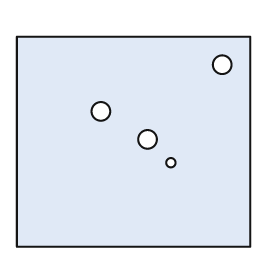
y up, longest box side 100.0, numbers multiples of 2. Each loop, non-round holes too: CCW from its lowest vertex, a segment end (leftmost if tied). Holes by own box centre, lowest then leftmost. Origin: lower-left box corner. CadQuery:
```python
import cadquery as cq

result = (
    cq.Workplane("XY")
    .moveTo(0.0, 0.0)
    .lineTo(100.0, 0.0)
    .lineTo(100.0, 90.0)
    .lineTo(0.0, 90.0)
    .close()
    .moveTo(66.0, 36.0)
    .circle(2.0)
    .moveTo(56.0, 46.0)
    .circle(4.0)
    .moveTo(36.0, 58.0)
    .circle(4.0)
    .moveTo(88.0, 78.0)
    .circle(4.0)
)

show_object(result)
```